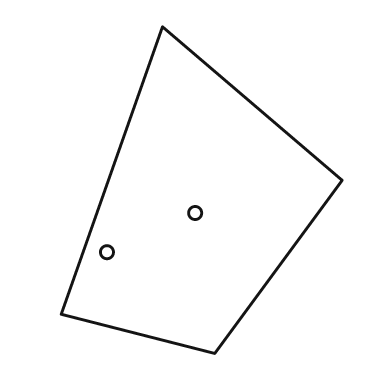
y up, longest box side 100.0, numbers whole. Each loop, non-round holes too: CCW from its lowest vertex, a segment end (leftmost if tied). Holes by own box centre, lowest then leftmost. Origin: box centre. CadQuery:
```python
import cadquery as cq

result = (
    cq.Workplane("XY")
    .moveTo(4.0, -50.0)
    .lineTo(43.0, 3.0)
    .lineTo(-12.0, 50.0)
    .lineTo(-43.0, -38.0)
    .close()
    .moveTo(-29.0, -19.0)
    .circle(2.0)
    .moveTo(-2.0, -7.0)
    .circle(2.0)
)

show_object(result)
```